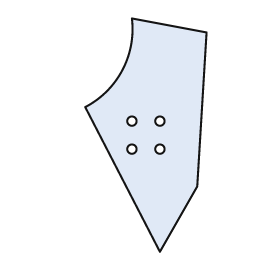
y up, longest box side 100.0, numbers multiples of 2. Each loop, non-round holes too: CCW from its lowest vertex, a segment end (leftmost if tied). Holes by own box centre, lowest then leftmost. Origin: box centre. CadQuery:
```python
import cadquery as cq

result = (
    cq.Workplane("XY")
    .moveTo(6.0, -50.0)
    .lineTo(22.0, -22.0)
    .lineTo(26.0, 44.0)
    .lineTo(-6.0, 50.0)
    .threePointArc((-10.0, 28.0), (-26.0, 12.0))
    .close()
    .moveTo(-6.0, -6.0)
    .circle(2.0)
    .moveTo(6.0, -6.0)
    .circle(2.0)
    .moveTo(-6.0, 6.0)
    .circle(2.0)
    .moveTo(6.0, 6.0)
    .circle(2.0)
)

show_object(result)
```